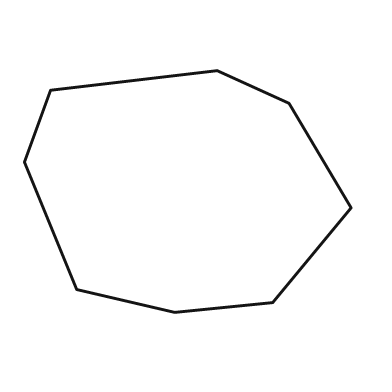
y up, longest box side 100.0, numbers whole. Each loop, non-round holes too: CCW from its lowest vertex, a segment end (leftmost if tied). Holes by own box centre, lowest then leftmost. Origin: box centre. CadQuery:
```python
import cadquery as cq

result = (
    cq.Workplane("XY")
    .moveTo(-4.0, -37.0)
    .lineTo(26.0, -34.0)
    .lineTo(50.0, -5.0)
    .lineTo(31.0, 27.0)
    .lineTo(9.0, 37.0)
    .lineTo(-42.0, 31.0)
    .lineTo(-50.0, 9.0)
    .lineTo(-34.0, -30.0)
    .close()
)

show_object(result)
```